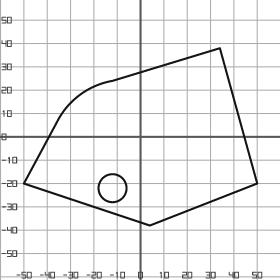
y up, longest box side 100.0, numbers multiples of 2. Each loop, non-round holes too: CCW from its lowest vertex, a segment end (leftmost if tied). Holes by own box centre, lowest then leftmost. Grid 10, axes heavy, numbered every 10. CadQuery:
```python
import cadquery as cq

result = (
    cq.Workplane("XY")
    .moveTo(4.0, -38.0)
    .lineTo(50.0, -20.0)
    .lineTo(34.0, 38.0)
    .lineTo(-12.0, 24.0)
    .threePointArc((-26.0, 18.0), (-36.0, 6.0))
    .lineTo(-50.0, -20.0)
    .close()
    .moveTo(-12.0, -22.0)
    .circle(6.0)
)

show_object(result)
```